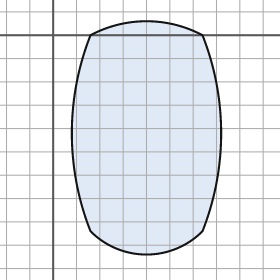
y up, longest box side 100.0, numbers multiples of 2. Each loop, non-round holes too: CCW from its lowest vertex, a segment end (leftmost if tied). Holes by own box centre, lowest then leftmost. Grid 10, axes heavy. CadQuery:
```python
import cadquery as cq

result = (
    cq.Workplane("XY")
    .moveTo(16.0, -84.0)
    .threePointArc((40.0, -94.0), (64.0, -84.0))
    .threePointArc((72.0, -42.0), (64.0, 0.0))
    .threePointArc((40.0, 6.0), (16.0, 0.0))
    .threePointArc((8.0, -42.0), (16.0, -84.0))
    .close()
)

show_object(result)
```